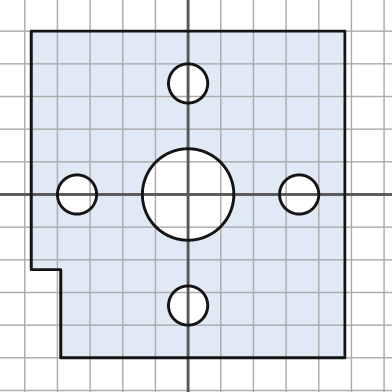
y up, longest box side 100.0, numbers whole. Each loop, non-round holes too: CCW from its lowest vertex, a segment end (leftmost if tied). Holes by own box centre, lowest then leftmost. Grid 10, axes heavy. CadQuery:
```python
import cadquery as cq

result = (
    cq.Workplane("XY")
    .moveTo(-39.0, -50.0)
    .lineTo(48.0, -50.0)
    .lineTo(48.0, 50.0)
    .lineTo(-48.0, 50.0)
    .lineTo(-48.0, -23.0)
    .lineTo(-39.0, -23.0)
    .close()
    .moveTo(0.0, -34.0)
    .circle(6.0)
    .moveTo(-34.0, 0.0)
    .circle(6.0)
    .moveTo(0.0, 0.0)
    .circle(14.0)
    .moveTo(34.0, 0.0)
    .circle(6.0)
    .moveTo(0.0, 34.0)
    .circle(6.0)
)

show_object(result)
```